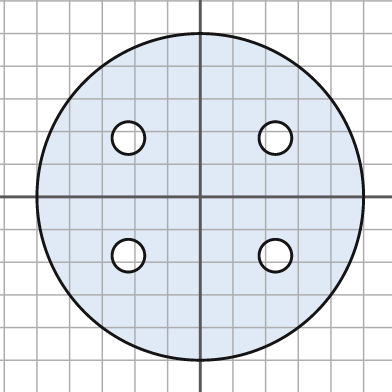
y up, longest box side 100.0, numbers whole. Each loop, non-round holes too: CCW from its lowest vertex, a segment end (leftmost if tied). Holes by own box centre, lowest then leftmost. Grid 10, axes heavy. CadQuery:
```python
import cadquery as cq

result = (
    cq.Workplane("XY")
    .moveTo(0.0, 0.0)
    .circle(50.0)
    .moveTo(-22.0, -18.0)
    .circle(5.0)
    .moveTo(23.0, -18.0)
    .circle(5.0)
    .moveTo(-22.0, 18.0)
    .circle(5.0)
    .moveTo(23.0, 18.0)
    .circle(5.0)
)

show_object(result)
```